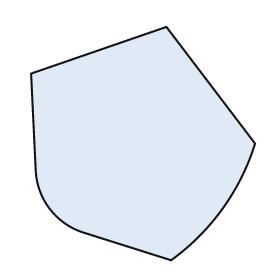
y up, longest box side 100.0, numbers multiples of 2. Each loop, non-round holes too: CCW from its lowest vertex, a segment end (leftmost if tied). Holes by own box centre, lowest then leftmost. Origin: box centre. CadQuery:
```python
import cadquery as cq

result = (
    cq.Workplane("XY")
    .moveTo(12.0, -50.0)
    .threePointArc((34.0, -28.0), (48.0, 0.0))
    .lineTo(10.0, 50.0)
    .lineTo(-48.0, 30.0)
    .lineTo(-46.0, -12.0)
    .threePointArc((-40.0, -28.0), (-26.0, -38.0))
    .close()
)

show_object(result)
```